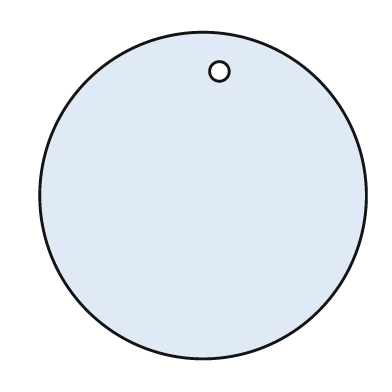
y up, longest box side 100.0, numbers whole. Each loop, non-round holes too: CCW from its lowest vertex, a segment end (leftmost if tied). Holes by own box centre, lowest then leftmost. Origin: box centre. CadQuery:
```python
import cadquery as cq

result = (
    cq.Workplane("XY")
    .moveTo(0.0, 0.0)
    .circle(50.0)
    .moveTo(5.0, 38.0)
    .circle(3.0)
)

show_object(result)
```